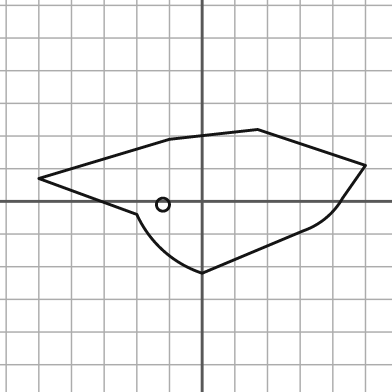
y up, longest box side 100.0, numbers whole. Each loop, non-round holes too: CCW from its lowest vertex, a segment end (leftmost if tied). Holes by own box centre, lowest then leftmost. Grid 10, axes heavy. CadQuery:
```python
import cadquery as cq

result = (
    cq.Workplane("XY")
    .moveTo(0.0, -22.0)
    .lineTo(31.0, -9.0)
    .threePointArc((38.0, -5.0), (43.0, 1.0))
    .lineTo(50.0, 11.0)
    .lineTo(17.0, 22.0)
    .lineTo(-10.0, 19.0)
    .lineTo(-50.0, 7.0)
    .lineTo(-20.0, -4.0)
    .threePointArc((-12.0, -15.0), (0.0, -22.0))
    .close()
    .moveTo(-12.0, -1.0)
    .circle(2.0)
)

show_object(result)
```